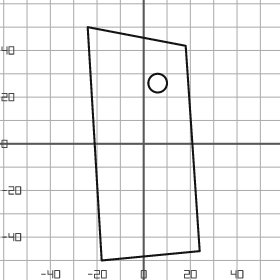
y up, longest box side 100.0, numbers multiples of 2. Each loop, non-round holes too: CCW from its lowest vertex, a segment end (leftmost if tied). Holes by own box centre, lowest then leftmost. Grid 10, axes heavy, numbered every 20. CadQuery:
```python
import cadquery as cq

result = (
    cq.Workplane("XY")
    .moveTo(-18.0, -50.0)
    .lineTo(24.0, -46.0)
    .lineTo(18.0, 42.0)
    .lineTo(-24.0, 50.0)
    .close()
    .moveTo(6.0, 26.0)
    .circle(4.0)
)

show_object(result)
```